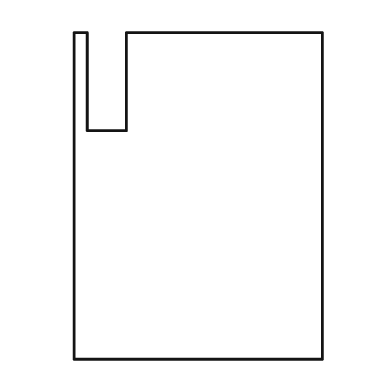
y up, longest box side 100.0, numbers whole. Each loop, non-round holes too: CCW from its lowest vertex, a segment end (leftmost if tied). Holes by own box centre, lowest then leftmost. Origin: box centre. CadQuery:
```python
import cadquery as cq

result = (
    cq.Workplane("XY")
    .moveTo(-38.0, -50.0)
    .lineTo(38.0, -50.0)
    .lineTo(38.0, 50.0)
    .lineTo(-22.0, 50.0)
    .lineTo(-22.0, 20.0)
    .lineTo(-34.0, 20.0)
    .lineTo(-34.0, 50.0)
    .lineTo(-38.0, 50.0)
    .close()
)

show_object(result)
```